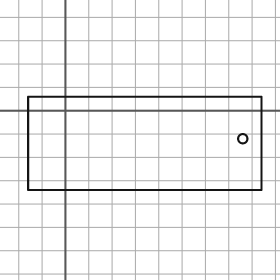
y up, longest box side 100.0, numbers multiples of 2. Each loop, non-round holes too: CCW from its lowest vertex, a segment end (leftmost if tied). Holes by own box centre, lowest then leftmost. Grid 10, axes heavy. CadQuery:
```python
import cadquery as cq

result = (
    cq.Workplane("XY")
    .moveTo(-16.0, -34.0)
    .lineTo(84.0, -34.0)
    .lineTo(84.0, 6.0)
    .lineTo(-16.0, 6.0)
    .close()
    .moveTo(76.0, -12.0)
    .circle(2.0)
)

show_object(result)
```